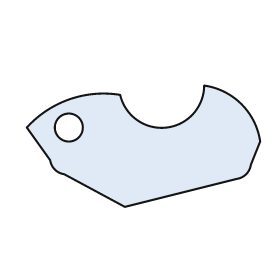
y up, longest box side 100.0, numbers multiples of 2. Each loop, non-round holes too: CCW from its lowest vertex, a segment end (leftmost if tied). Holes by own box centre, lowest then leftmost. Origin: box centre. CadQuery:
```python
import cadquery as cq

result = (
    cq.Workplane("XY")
    .moveTo(-8.0, -26.0)
    .lineTo(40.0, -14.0)
    .threePointArc((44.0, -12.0), (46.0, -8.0))
    .lineTo(50.0, 2.0)
    .threePointArc((42.0, 18.0), (26.0, 26.0))
    .threePointArc((10.0, 8.0), (-10.0, 22.0))
    .threePointArc((-32.0, 20.0), (-50.0, 8.0))
    .lineTo(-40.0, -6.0)
    .threePointArc((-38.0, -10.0), (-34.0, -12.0))
    .close()
    .moveTo(-32.0, 8.0)
    .circle(6.0)
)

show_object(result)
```